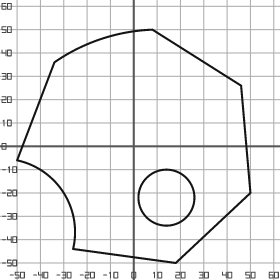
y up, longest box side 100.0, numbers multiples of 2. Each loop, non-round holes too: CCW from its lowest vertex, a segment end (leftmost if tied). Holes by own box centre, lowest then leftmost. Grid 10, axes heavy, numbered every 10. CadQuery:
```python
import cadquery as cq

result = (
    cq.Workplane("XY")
    .moveTo(18.0, -50.0)
    .lineTo(50.0, -20.0)
    .lineTo(46.0, 26.0)
    .lineTo(8.0, 50.0)
    .threePointArc((-14.0, 46.0), (-34.0, 36.0))
    .lineTo(-50.0, -6.0)
    .threePointArc((-30.0, -20.0), (-26.0, -44.0))
    .close()
    .moveTo(14.0, -22.0)
    .circle(12.0)
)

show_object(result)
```